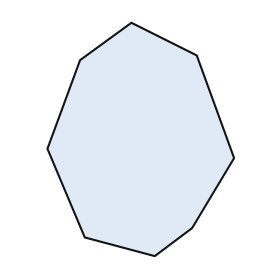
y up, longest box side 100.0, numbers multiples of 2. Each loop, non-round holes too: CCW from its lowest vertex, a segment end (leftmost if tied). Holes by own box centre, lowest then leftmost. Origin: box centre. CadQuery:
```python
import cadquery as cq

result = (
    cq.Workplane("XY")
    .moveTo(6.0, -50.0)
    .lineTo(22.0, -38.0)
    .lineTo(40.0, -8.0)
    .lineTo(24.0, 36.0)
    .lineTo(-4.0, 50.0)
    .lineTo(-26.0, 34.0)
    .lineTo(-40.0, -4.0)
    .lineTo(-24.0, -42.0)
    .close()
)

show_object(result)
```